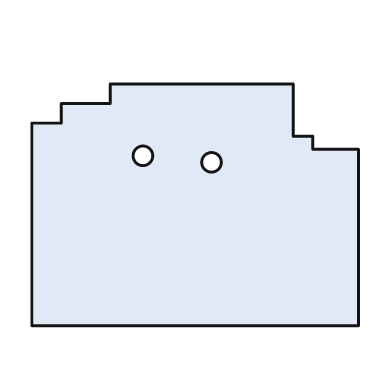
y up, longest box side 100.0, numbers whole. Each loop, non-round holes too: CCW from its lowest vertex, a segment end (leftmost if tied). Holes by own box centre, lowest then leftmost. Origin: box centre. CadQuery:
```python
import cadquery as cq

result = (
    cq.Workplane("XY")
    .moveTo(-50.0, -37.0)
    .lineTo(50.0, -37.0)
    .lineTo(50.0, 17.0)
    .lineTo(36.0, 17.0)
    .lineTo(36.0, 21.0)
    .lineTo(30.0, 21.0)
    .lineTo(30.0, 37.0)
    .lineTo(-26.0, 37.0)
    .lineTo(-26.0, 31.0)
    .lineTo(-41.0, 31.0)
    .lineTo(-41.0, 25.0)
    .lineTo(-50.0, 25.0)
    .close()
    .moveTo(5.0, 13.0)
    .circle(3.0)
    .moveTo(-16.0, 15.0)
    .circle(3.0)
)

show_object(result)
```